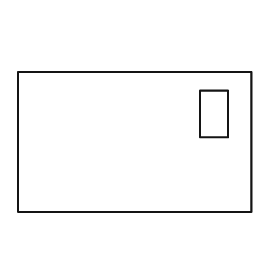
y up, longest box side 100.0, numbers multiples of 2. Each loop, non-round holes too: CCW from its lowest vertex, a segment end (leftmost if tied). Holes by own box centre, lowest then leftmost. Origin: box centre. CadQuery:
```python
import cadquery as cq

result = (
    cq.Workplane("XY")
    .moveTo(-50.0, -30.0)
    .lineTo(50.0, -30.0)
    .lineTo(50.0, 30.0)
    .lineTo(-50.0, 30.0)
    .close()
    .moveTo(28.0, 2.0)
    .lineTo(40.0, 2.0)
    .lineTo(40.0, 22.0)
    .lineTo(28.0, 22.0)
    .close()
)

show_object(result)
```